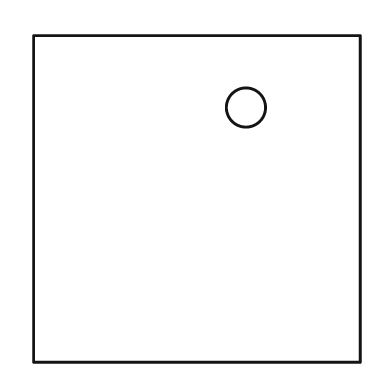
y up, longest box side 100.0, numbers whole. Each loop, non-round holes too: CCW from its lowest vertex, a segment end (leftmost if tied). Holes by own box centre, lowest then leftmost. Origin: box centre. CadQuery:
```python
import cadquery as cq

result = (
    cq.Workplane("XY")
    .moveTo(-50.0, -50.0)
    .lineTo(50.0, -50.0)
    .lineTo(50.0, 50.0)
    .lineTo(-50.0, 50.0)
    .close()
    .moveTo(15.0, 28.0)
    .circle(6.0)
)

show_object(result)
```